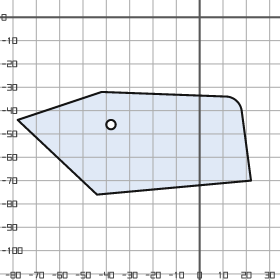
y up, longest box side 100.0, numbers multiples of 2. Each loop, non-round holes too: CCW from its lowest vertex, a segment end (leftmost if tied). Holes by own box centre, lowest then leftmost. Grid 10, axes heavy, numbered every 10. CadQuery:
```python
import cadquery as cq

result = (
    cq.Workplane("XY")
    .moveTo(-44.0, -76.0)
    .lineTo(22.0, -70.0)
    .lineTo(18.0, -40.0)
    .threePointArc((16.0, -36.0), (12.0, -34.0))
    .lineTo(-42.0, -32.0)
    .lineTo(-78.0, -44.0)
    .close()
    .moveTo(-38.0, -46.0)
    .circle(2.0)
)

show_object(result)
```